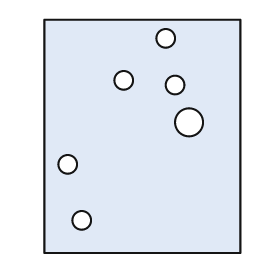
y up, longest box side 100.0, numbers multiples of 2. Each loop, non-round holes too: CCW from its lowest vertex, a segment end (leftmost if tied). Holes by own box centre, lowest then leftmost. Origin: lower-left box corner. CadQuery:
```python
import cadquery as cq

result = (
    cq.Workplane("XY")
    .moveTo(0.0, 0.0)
    .lineTo(84.0, 0.0)
    .lineTo(84.0, 100.0)
    .lineTo(0.0, 100.0)
    .close()
    .moveTo(16.0, 14.0)
    .circle(4.0)
    .moveTo(10.0, 38.0)
    .circle(4.0)
    .moveTo(62.0, 56.0)
    .circle(6.0)
    .moveTo(56.0, 72.0)
    .circle(4.0)
    .moveTo(34.0, 74.0)
    .circle(4.0)
    .moveTo(52.0, 92.0)
    .circle(4.0)
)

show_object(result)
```